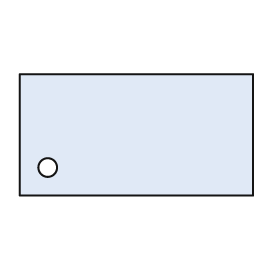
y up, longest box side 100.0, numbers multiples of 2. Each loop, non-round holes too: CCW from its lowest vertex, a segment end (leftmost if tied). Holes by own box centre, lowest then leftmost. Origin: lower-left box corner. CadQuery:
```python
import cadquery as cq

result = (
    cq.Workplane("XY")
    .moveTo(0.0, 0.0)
    .lineTo(100.0, 0.0)
    .lineTo(100.0, 52.0)
    .lineTo(0.0, 52.0)
    .close()
    .moveTo(12.0, 12.0)
    .circle(4.0)
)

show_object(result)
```